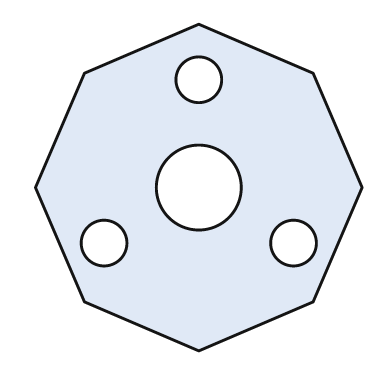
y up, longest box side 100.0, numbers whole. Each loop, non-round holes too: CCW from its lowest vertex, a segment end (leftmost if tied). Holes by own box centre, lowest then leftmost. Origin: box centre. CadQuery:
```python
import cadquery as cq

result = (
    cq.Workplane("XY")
    .moveTo(0.0, -50.0)
    .lineTo(35.0, -35.0)
    .lineTo(50.0, 0.0)
    .lineTo(35.0, 35.0)
    .lineTo(0.0, 50.0)
    .lineTo(-35.0, 35.0)
    .lineTo(-50.0, 0.0)
    .lineTo(-35.0, -35.0)
    .close()
    .moveTo(-29.0, -17.0)
    .circle(7.0)
    .moveTo(29.0, -17.0)
    .circle(7.0)
    .moveTo(0.0, 0.0)
    .circle(13.0)
    .moveTo(0.0, 33.0)
    .circle(7.0)
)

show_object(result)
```